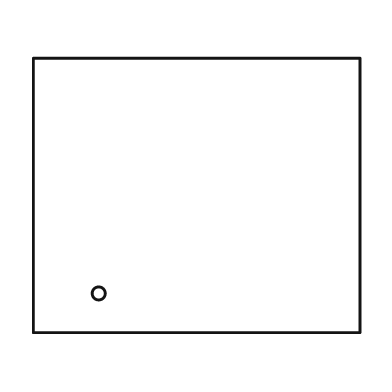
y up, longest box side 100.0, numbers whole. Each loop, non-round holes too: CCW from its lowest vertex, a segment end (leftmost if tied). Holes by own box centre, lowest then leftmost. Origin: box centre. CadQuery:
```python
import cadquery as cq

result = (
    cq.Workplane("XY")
    .moveTo(-50.0, -42.0)
    .lineTo(50.0, -42.0)
    .lineTo(50.0, 42.0)
    .lineTo(-50.0, 42.0)
    .close()
    .moveTo(-30.0, -30.0)
    .circle(2.0)
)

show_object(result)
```